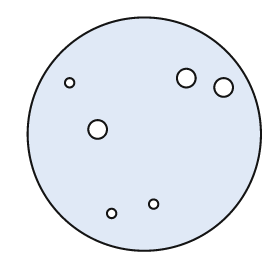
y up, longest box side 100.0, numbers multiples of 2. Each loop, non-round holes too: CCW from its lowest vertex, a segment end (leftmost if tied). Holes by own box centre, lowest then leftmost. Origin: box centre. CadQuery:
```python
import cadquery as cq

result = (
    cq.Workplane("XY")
    .moveTo(0.0, 0.0)
    .circle(50.0)
    .moveTo(-14.0, -34.0)
    .circle(2.0)
    .moveTo(4.0, -30.0)
    .circle(2.0)
    .moveTo(-20.0, 2.0)
    .circle(4.0)
    .moveTo(34.0, 20.0)
    .circle(4.0)
    .moveTo(-32.0, 22.0)
    .circle(2.0)
    .moveTo(18.0, 24.0)
    .circle(4.0)
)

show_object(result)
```